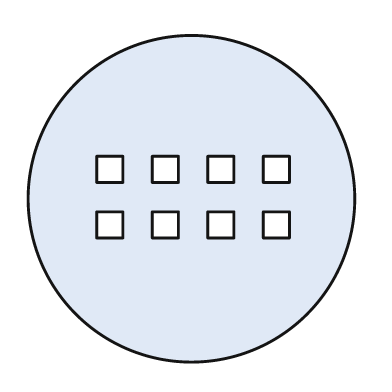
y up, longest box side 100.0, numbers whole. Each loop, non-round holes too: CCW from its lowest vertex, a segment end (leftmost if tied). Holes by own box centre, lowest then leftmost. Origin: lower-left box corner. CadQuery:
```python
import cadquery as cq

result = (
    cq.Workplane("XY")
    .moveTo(50.0, 50.0)
    .circle(50.0)
    .moveTo(21.0, 38.0)
    .lineTo(29.0, 38.0)
    .lineTo(29.0, 46.0)
    .lineTo(21.0, 46.0)
    .close()
    .moveTo(38.0, 38.0)
    .lineTo(46.0, 38.0)
    .lineTo(46.0, 46.0)
    .lineTo(38.0, 46.0)
    .close()
    .moveTo(55.0, 38.0)
    .lineTo(63.0, 38.0)
    .lineTo(63.0, 46.0)
    .lineTo(55.0, 46.0)
    .close()
    .moveTo(72.0, 38.0)
    .lineTo(80.0, 38.0)
    .lineTo(80.0, 46.0)
    .lineTo(72.0, 46.0)
    .close()
    .moveTo(21.0, 55.0)
    .lineTo(29.0, 55.0)
    .lineTo(29.0, 63.0)
    .lineTo(21.0, 63.0)
    .close()
    .moveTo(38.0, 55.0)
    .lineTo(46.0, 55.0)
    .lineTo(46.0, 63.0)
    .lineTo(38.0, 63.0)
    .close()
    .moveTo(55.0, 55.0)
    .lineTo(63.0, 55.0)
    .lineTo(63.0, 63.0)
    .lineTo(55.0, 63.0)
    .close()
    .moveTo(72.0, 55.0)
    .lineTo(80.0, 55.0)
    .lineTo(80.0, 63.0)
    .lineTo(72.0, 63.0)
    .close()
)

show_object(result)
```